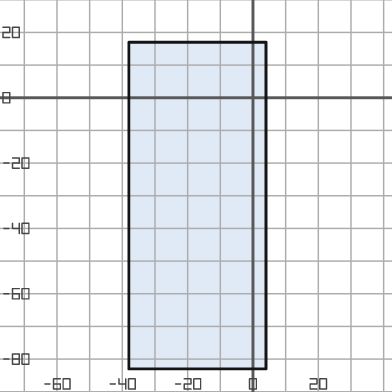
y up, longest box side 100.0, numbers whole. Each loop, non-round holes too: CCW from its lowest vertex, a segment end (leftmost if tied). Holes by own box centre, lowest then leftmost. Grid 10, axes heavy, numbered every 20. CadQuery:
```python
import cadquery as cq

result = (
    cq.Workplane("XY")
    .moveTo(-38.0, -83.0)
    .lineTo(4.0, -83.0)
    .lineTo(4.0, 17.0)
    .lineTo(-38.0, 17.0)
    .close()
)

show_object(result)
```